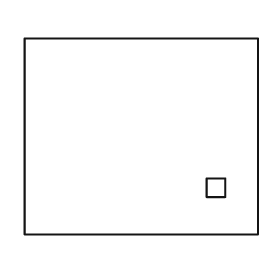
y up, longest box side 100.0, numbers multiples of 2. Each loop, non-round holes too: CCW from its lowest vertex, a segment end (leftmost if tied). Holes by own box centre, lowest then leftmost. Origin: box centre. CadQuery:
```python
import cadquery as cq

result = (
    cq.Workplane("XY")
    .moveTo(-50.0, -42.0)
    .lineTo(50.0, -42.0)
    .lineTo(50.0, 42.0)
    .lineTo(-50.0, 42.0)
    .close()
    .moveTo(28.0, -26.0)
    .lineTo(36.0, -26.0)
    .lineTo(36.0, -18.0)
    .lineTo(28.0, -18.0)
    .close()
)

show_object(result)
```